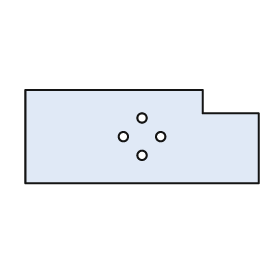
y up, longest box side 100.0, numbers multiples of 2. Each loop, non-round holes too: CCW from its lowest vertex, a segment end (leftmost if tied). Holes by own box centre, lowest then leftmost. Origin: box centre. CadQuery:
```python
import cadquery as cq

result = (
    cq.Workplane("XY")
    .moveTo(-50.0, -20.0)
    .lineTo(50.0, -20.0)
    .lineTo(50.0, 10.0)
    .lineTo(26.0, 10.0)
    .lineTo(26.0, 20.0)
    .lineTo(-50.0, 20.0)
    .close()
    .moveTo(0.0, -8.0)
    .circle(2.0)
    .moveTo(-8.0, 0.0)
    .circle(2.0)
    .moveTo(8.0, 0.0)
    .circle(2.0)
    .moveTo(0.0, 8.0)
    .circle(2.0)
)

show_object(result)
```